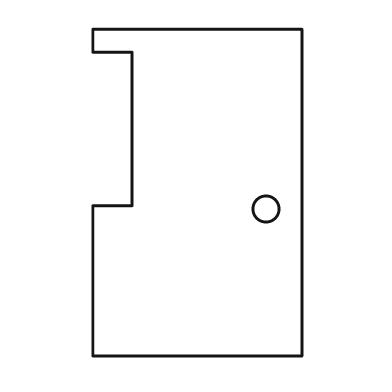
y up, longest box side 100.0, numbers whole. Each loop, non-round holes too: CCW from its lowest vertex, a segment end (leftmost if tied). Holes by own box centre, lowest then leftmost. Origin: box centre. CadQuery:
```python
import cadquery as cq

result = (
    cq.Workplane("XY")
    .moveTo(-32.0, -50.0)
    .lineTo(32.0, -50.0)
    .lineTo(32.0, 50.0)
    .lineTo(-32.0, 50.0)
    .lineTo(-32.0, 43.0)
    .lineTo(-20.0, 43.0)
    .lineTo(-20.0, -4.0)
    .lineTo(-32.0, -4.0)
    .close()
    .moveTo(21.0, -5.0)
    .circle(4.0)
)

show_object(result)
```